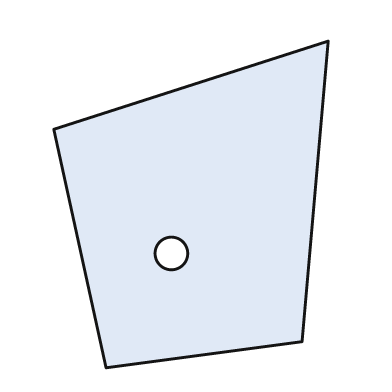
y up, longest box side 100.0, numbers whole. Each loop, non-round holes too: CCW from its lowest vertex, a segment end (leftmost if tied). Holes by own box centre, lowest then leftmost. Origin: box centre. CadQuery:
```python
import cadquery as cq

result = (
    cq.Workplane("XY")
    .moveTo(-26.0, -50.0)
    .lineTo(34.0, -42.0)
    .lineTo(42.0, 50.0)
    .lineTo(-42.0, 23.0)
    .close()
    .moveTo(-6.0, -15.0)
    .circle(5.0)
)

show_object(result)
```